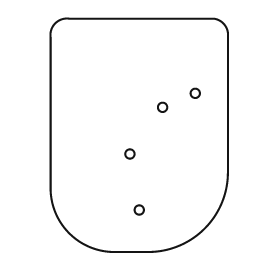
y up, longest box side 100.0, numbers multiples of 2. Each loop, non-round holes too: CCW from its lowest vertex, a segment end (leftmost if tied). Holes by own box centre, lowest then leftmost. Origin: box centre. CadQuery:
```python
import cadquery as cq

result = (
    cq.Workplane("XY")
    .moveTo(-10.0, -50.0)
    .lineTo(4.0, -50.0)
    .threePointArc((28.0, -40.0), (38.0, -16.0))
    .lineTo(38.0, 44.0)
    .threePointArc((36.0, 48.0), (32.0, 50.0))
    .lineTo(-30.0, 50.0)
    .threePointArc((-36.0, 48.0), (-38.0, 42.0))
    .lineTo(-38.0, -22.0)
    .threePointArc((-30.0, -42.0), (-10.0, -50.0))
    .close()
    .moveTo(0.0, -32.0)
    .circle(2.0)
    .moveTo(-4.0, -8.0)
    .circle(2.0)
    .moveTo(10.0, 12.0)
    .circle(2.0)
    .moveTo(24.0, 18.0)
    .circle(2.0)
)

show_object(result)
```